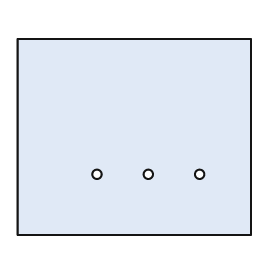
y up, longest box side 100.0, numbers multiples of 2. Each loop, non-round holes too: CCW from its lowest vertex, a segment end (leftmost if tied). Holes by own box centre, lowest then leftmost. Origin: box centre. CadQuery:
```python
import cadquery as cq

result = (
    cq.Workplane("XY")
    .moveTo(-50.0, -42.0)
    .lineTo(50.0, -42.0)
    .lineTo(50.0, 42.0)
    .lineTo(-50.0, 42.0)
    .close()
    .moveTo(-16.0, -16.0)
    .circle(2.0)
    .moveTo(6.0, -16.0)
    .circle(2.0)
    .moveTo(28.0, -16.0)
    .circle(2.0)
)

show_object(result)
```